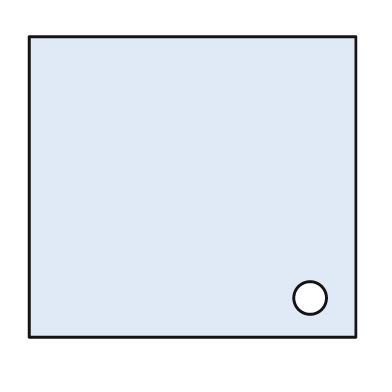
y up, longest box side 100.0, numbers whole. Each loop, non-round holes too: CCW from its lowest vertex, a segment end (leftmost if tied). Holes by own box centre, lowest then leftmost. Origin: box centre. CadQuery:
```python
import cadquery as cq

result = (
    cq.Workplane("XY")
    .moveTo(-50.0, -46.0)
    .lineTo(50.0, -46.0)
    .lineTo(50.0, 46.0)
    .lineTo(-50.0, 46.0)
    .close()
    .moveTo(36.0, -34.0)
    .circle(5.0)
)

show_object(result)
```